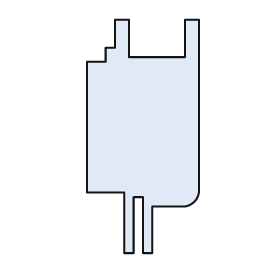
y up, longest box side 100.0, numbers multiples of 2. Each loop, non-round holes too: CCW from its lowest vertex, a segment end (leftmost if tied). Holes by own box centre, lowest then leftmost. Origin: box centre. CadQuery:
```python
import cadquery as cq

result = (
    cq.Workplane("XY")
    .moveTo(-8.0, -50.0)
    .lineTo(-4.0, -50.0)
    .lineTo(-4.0, -26.0)
    .lineTo(0.0, -26.0)
    .lineTo(0.0, -50.0)
    .lineTo(4.0, -50.0)
    .lineTo(4.0, -30.0)
    .lineTo(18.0, -30.0)
    .threePointArc((22.0, -28.0), (24.0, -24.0))
    .lineTo(24.0, 50.0)
    .lineTo(18.0, 50.0)
    .lineTo(18.0, 34.0)
    .lineTo(-6.0, 34.0)
    .lineTo(-6.0, 50.0)
    .lineTo(-12.0, 50.0)
    .lineTo(-12.0, 38.0)
    .lineTo(-16.0, 38.0)
    .lineTo(-16.0, 32.0)
    .lineTo(-24.0, 32.0)
    .lineTo(-24.0, -24.0)
    .lineTo(-8.0, -24.0)
    .close()
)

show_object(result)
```